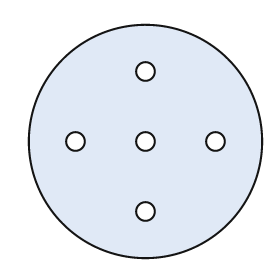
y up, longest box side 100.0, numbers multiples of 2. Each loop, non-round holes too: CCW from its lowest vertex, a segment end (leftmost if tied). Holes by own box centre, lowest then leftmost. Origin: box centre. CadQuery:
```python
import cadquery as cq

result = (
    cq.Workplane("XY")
    .moveTo(0.0, 0.0)
    .circle(50.0)
    .moveTo(0.0, -30.0)
    .circle(4.0)
    .moveTo(-30.0, 0.0)
    .circle(4.0)
    .moveTo(0.0, 0.0)
    .circle(4.0)
    .moveTo(30.0, 0.0)
    .circle(4.0)
    .moveTo(0.0, 30.0)
    .circle(4.0)
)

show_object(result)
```